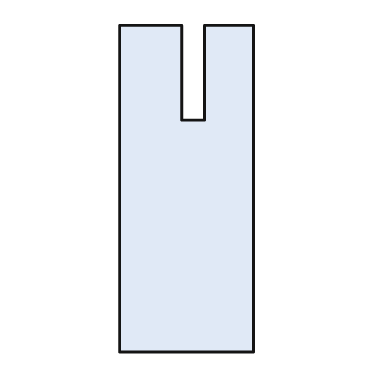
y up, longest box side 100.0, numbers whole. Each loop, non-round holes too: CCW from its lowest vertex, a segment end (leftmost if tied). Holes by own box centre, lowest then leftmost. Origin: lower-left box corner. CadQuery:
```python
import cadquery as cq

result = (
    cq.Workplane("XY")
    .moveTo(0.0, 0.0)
    .lineTo(41.0, 0.0)
    .lineTo(41.0, 100.0)
    .lineTo(26.0, 100.0)
    .lineTo(26.0, 71.0)
    .lineTo(19.0, 71.0)
    .lineTo(19.0, 100.0)
    .lineTo(0.0, 100.0)
    .close()
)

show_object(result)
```